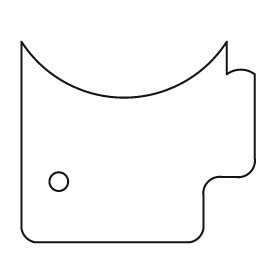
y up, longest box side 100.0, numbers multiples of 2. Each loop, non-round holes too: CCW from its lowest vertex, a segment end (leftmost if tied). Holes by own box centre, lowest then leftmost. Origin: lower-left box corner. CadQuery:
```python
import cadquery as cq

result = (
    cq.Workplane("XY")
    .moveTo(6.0, 0.0)
    .lineTo(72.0, 0.0)
    .threePointArc((76.0, 2.0), (78.0, 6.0))
    .lineTo(78.0, 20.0)
    .threePointArc((80.0, 26.0), (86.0, 28.0))
    .lineTo(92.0, 28.0)
    .threePointArc((98.0, 30.0), (100.0, 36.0))
    .lineTo(100.0, 72.0)
    .threePointArc((94.0, 74.0), (88.0, 72.0))
    .lineTo(88.0, 86.0)
    .threePointArc((44.0, 62.0), (0.0, 86.0))
    .lineTo(0.0, 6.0)
    .threePointArc((2.0, 2.0), (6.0, 0.0))
    .close()
    .moveTo(16.0, 26.0)
    .circle(4.0)
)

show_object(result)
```